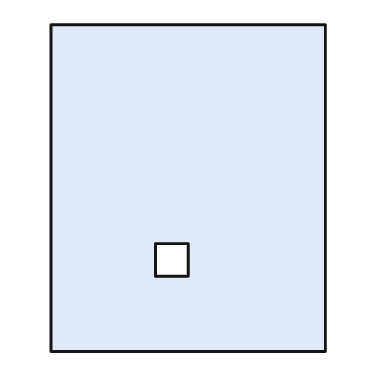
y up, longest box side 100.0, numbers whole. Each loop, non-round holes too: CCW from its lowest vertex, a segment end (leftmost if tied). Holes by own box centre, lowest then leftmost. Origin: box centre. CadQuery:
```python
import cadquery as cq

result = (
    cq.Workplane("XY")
    .moveTo(-42.0, -50.0)
    .lineTo(42.0, -50.0)
    .lineTo(42.0, 50.0)
    .lineTo(-42.0, 50.0)
    .close()
    .moveTo(-10.0, -27.0)
    .lineTo(0.0, -27.0)
    .lineTo(0.0, -17.0)
    .lineTo(-10.0, -17.0)
    .close()
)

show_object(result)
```